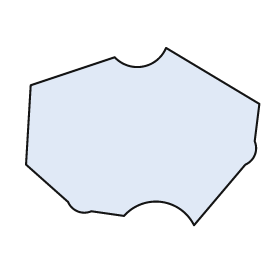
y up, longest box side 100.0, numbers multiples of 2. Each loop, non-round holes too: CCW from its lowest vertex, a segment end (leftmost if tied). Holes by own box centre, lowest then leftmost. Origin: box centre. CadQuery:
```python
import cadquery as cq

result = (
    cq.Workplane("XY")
    .moveTo(22.0, -38.0)
    .lineTo(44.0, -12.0)
    .threePointArc((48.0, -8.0), (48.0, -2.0))
    .lineTo(50.0, 14.0)
    .lineTo(10.0, 38.0)
    .threePointArc((0.0, 30.0), (-12.0, 34.0))
    .lineTo(-48.0, 22.0)
    .lineTo(-50.0, -12.0)
    .lineTo(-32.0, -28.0)
    .threePointArc((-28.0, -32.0), (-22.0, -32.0))
    .lineTo(-8.0, -34.0)
    .threePointArc((8.0, -28.0), (22.0, -38.0))
    .close()
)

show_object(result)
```